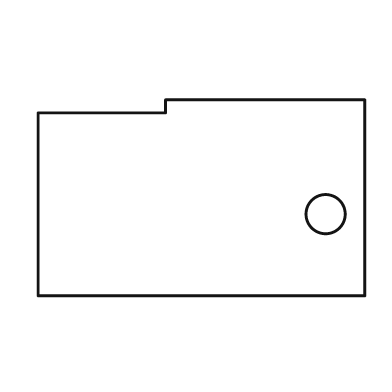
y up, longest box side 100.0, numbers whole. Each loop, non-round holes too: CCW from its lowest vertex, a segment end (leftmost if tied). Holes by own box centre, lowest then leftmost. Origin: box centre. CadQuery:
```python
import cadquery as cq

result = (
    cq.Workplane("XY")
    .moveTo(-50.0, -30.0)
    .lineTo(50.0, -30.0)
    .lineTo(50.0, 30.0)
    .lineTo(-11.0, 30.0)
    .lineTo(-11.0, 26.0)
    .lineTo(-50.0, 26.0)
    .close()
    .moveTo(38.0, -5.0)
    .circle(6.0)
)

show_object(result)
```